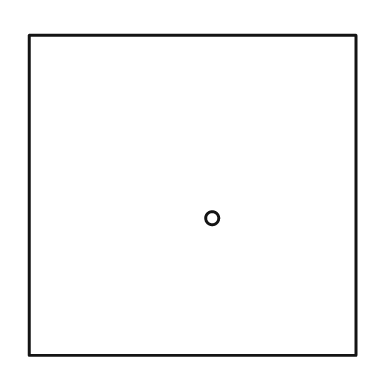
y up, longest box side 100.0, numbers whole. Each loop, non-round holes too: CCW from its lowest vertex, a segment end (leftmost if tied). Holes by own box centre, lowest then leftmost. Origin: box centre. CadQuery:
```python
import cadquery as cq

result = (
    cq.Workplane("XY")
    .moveTo(-50.0, -49.0)
    .lineTo(50.0, -49.0)
    .lineTo(50.0, 49.0)
    .lineTo(-50.0, 49.0)
    .close()
    .moveTo(6.0, -7.0)
    .circle(2.0)
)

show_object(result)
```